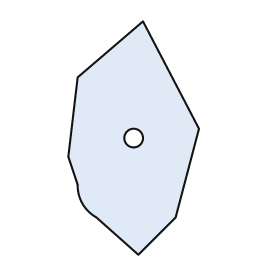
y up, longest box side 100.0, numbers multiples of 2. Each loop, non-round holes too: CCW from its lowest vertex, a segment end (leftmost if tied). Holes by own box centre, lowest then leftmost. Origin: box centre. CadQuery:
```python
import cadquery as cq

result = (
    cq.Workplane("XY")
    .moveTo(2.0, -50.0)
    .lineTo(18.0, -34.0)
    .lineTo(28.0, 4.0)
    .lineTo(4.0, 50.0)
    .lineTo(-24.0, 26.0)
    .lineTo(-28.0, -8.0)
    .lineTo(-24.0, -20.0)
    .threePointArc((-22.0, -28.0), (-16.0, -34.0))
    .close()
    .moveTo(0.0, 0.0)
    .circle(4.0)
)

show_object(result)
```